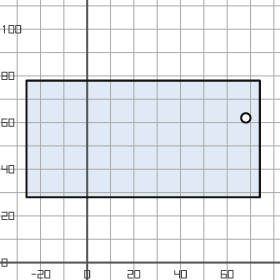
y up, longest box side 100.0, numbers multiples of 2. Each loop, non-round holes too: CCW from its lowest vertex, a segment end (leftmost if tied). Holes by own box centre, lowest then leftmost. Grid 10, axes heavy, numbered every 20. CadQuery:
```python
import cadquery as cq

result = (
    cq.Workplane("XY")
    .moveTo(-26.0, 28.0)
    .lineTo(74.0, 28.0)
    .lineTo(74.0, 78.0)
    .lineTo(-26.0, 78.0)
    .close()
    .moveTo(68.0, 62.0)
    .circle(2.0)
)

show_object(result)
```